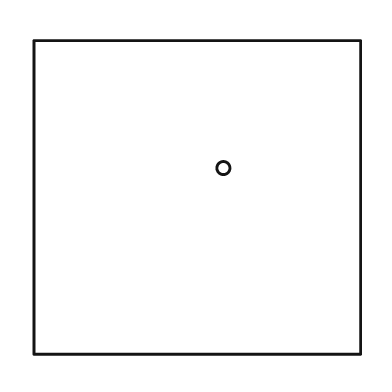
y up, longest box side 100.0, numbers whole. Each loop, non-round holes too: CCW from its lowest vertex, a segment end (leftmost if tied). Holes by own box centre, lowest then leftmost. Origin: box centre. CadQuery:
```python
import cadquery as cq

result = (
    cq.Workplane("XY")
    .moveTo(-50.0, -48.0)
    .lineTo(50.0, -48.0)
    .lineTo(50.0, 48.0)
    .lineTo(-50.0, 48.0)
    .close()
    .moveTo(8.0, 9.0)
    .circle(2.0)
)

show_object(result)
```